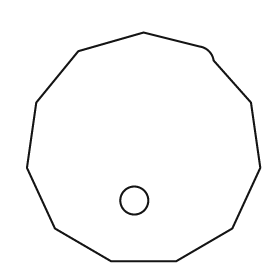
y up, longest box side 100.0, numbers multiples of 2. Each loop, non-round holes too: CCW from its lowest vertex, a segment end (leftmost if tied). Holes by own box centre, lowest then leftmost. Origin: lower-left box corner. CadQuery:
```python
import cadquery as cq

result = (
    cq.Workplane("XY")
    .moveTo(36.0, 0.0)
    .lineTo(64.0, 0.0)
    .lineTo(88.0, 14.0)
    .lineTo(100.0, 40.0)
    .lineTo(96.0, 68.0)
    .lineTo(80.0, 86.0)
    .threePointArc((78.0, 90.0), (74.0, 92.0))
    .lineTo(50.0, 98.0)
    .lineTo(22.0, 90.0)
    .lineTo(4.0, 68.0)
    .lineTo(0.0, 40.0)
    .lineTo(12.0, 14.0)
    .close()
    .moveTo(46.0, 26.0)
    .circle(6.0)
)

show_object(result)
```